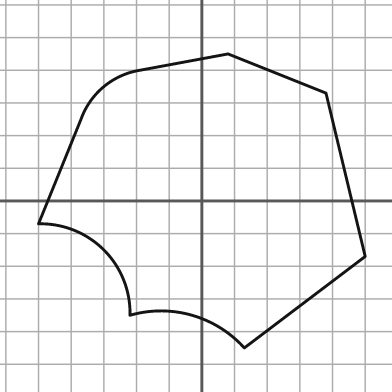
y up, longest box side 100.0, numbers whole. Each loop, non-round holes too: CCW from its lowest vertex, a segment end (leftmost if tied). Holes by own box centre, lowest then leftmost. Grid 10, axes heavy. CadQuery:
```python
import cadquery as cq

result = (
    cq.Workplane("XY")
    .moveTo(13.0, -45.0)
    .lineTo(50.0, -17.0)
    .lineTo(38.0, 33.0)
    .lineTo(8.0, 45.0)
    .lineTo(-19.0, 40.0)
    .threePointArc((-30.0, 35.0), (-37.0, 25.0))
    .lineTo(-50.0, -7.0)
    .threePointArc((-30.0, -15.0), (-22.0, -35.0))
    .threePointArc((-3.0, -35.0), (13.0, -45.0))
    .close()
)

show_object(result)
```